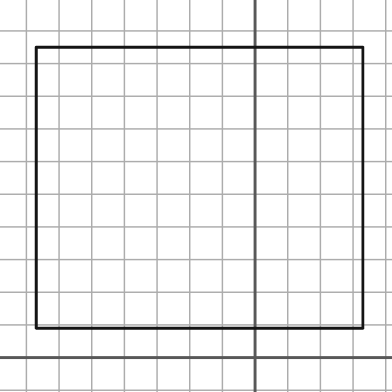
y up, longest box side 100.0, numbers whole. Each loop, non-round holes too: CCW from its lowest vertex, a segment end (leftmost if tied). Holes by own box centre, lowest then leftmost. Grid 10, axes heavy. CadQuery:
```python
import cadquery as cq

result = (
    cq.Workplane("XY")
    .moveTo(-67.0, 9.0)
    .lineTo(33.0, 9.0)
    .lineTo(33.0, 95.0)
    .lineTo(-67.0, 95.0)
    .close()
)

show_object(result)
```